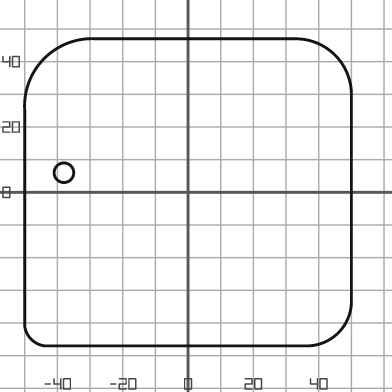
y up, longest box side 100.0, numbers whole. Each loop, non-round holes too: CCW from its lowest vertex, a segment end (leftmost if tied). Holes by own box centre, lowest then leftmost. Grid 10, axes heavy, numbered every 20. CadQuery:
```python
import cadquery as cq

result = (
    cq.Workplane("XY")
    .moveTo(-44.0, -47.0)
    .lineTo(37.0, -47.0)
    .threePointArc((46.0, -43.0), (50.0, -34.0))
    .lineTo(50.0, 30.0)
    .threePointArc((45.0, 42.0), (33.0, 47.0))
    .lineTo(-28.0, 47.0)
    .threePointArc((-44.0, 41.0), (-50.0, 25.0))
    .lineTo(-50.0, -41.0)
    .threePointArc((-48.0, -45.0), (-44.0, -47.0))
    .close()
    .moveTo(-38.0, 6.0)
    .circle(3.0)
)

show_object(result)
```